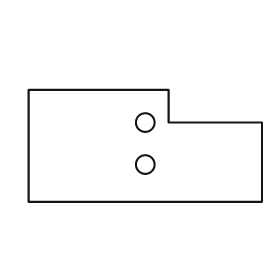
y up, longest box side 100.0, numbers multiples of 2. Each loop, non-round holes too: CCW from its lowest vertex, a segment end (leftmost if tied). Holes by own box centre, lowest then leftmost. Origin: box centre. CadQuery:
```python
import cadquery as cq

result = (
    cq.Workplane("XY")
    .moveTo(-50.0, -24.0)
    .lineTo(50.0, -24.0)
    .lineTo(50.0, 10.0)
    .lineTo(10.0, 10.0)
    .lineTo(10.0, 24.0)
    .lineTo(-50.0, 24.0)
    .close()
    .moveTo(0.0, -8.0)
    .circle(4.0)
    .moveTo(0.0, 10.0)
    .circle(4.0)
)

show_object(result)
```